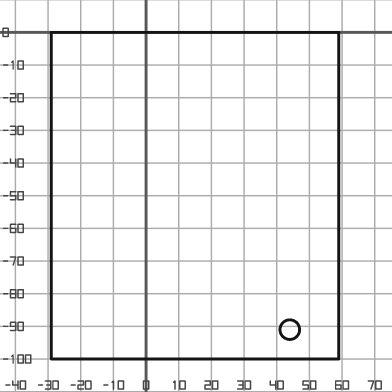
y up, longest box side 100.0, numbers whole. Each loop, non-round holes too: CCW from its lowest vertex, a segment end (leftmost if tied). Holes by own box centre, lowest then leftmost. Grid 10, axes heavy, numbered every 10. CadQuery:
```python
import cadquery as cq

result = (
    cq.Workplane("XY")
    .moveTo(-29.0, -100.0)
    .lineTo(59.0, -100.0)
    .lineTo(59.0, 0.0)
    .lineTo(-29.0, 0.0)
    .close()
    .moveTo(44.0, -91.0)
    .circle(3.0)
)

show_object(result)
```